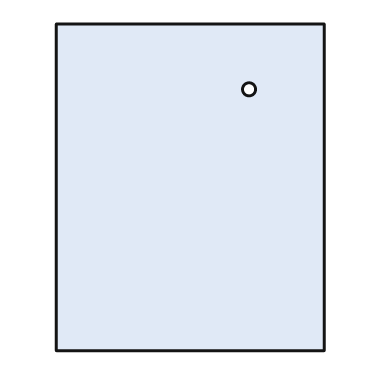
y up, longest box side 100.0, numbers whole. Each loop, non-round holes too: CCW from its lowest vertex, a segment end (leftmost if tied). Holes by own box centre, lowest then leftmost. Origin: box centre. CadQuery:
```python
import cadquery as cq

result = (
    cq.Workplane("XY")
    .moveTo(-41.0, -50.0)
    .lineTo(41.0, -50.0)
    .lineTo(41.0, 50.0)
    .lineTo(-41.0, 50.0)
    .close()
    .moveTo(18.0, 30.0)
    .circle(2.0)
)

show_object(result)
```